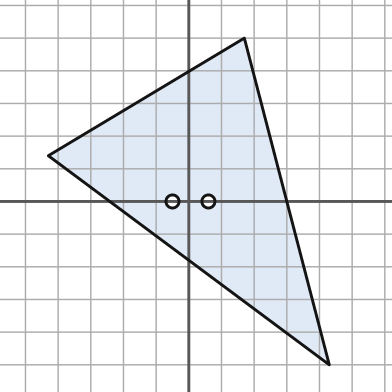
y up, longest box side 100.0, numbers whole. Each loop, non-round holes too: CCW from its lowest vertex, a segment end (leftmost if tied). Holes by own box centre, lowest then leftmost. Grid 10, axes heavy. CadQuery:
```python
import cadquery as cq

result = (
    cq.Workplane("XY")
    .moveTo(43.0, -50.0)
    .lineTo(17.0, 50.0)
    .lineTo(-43.0, 14.0)
    .close()
    .moveTo(-5.0, 0.0)
    .circle(2.0)
    .moveTo(6.0, 0.0)
    .circle(2.0)
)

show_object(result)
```